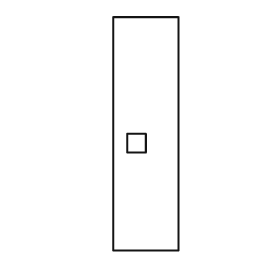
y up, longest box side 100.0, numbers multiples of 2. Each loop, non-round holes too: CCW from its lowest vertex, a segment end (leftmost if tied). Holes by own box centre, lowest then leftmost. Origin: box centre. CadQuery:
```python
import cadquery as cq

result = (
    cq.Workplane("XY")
    .moveTo(-14.0, -50.0)
    .lineTo(14.0, -50.0)
    .lineTo(14.0, 50.0)
    .lineTo(-14.0, 50.0)
    .close()
    .moveTo(-8.0, -8.0)
    .lineTo(0.0, -8.0)
    .lineTo(0.0, 0.0)
    .lineTo(-8.0, 0.0)
    .close()
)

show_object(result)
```